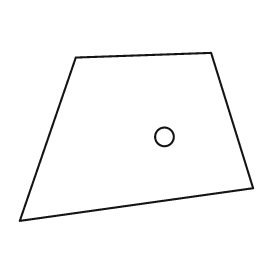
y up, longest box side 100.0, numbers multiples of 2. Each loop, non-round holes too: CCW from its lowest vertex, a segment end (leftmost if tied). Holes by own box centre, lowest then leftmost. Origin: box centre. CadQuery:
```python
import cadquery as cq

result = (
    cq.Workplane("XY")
    .moveTo(-50.0, -36.0)
    .lineTo(50.0, -22.0)
    .lineTo(32.0, 36.0)
    .lineTo(-26.0, 34.0)
    .close()
    .moveTo(12.0, 0.0)
    .circle(4.0)
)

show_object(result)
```